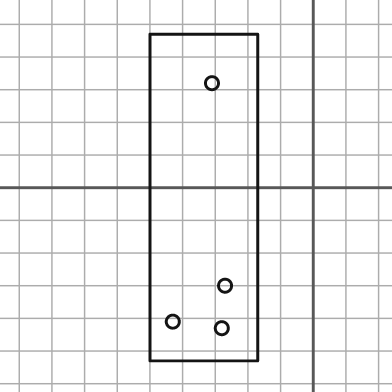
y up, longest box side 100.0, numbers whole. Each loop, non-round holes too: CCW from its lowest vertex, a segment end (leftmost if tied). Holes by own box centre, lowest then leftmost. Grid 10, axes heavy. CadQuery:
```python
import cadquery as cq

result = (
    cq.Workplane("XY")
    .moveTo(-50.0, -53.0)
    .lineTo(-17.0, -53.0)
    .lineTo(-17.0, 47.0)
    .lineTo(-50.0, 47.0)
    .close()
    .moveTo(-28.0, -43.0)
    .circle(2.0)
    .moveTo(-43.0, -41.0)
    .circle(2.0)
    .moveTo(-27.0, -30.0)
    .circle(2.0)
    .moveTo(-31.0, 32.0)
    .circle(2.0)
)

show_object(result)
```